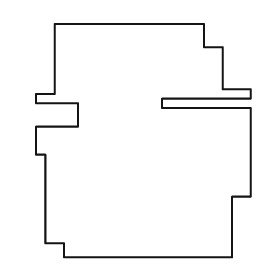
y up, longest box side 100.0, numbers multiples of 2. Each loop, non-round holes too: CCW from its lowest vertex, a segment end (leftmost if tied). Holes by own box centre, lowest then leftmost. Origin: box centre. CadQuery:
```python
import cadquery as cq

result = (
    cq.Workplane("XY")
    .moveTo(-34.0, -50.0)
    .lineTo(38.0, -50.0)
    .lineTo(38.0, -24.0)
    .lineTo(46.0, -24.0)
    .lineTo(46.0, 14.0)
    .lineTo(8.0, 14.0)
    .lineTo(8.0, 18.0)
    .lineTo(46.0, 18.0)
    .lineTo(46.0, 22.0)
    .lineTo(34.0, 22.0)
    .lineTo(34.0, 40.0)
    .lineTo(26.0, 40.0)
    .lineTo(26.0, 50.0)
    .lineTo(-38.0, 50.0)
    .lineTo(-38.0, 20.0)
    .lineTo(-46.0, 20.0)
    .lineTo(-46.0, 16.0)
    .lineTo(-28.0, 16.0)
    .lineTo(-28.0, 6.0)
    .lineTo(-46.0, 6.0)
    .lineTo(-46.0, -6.0)
    .lineTo(-42.0, -6.0)
    .lineTo(-42.0, -44.0)
    .lineTo(-34.0, -44.0)
    .close()
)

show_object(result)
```